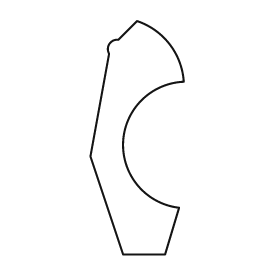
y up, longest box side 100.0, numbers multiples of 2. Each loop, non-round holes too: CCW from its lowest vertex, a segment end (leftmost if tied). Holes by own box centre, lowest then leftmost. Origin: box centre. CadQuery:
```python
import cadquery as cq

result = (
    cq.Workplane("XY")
    .moveTo(-6.0, -50.0)
    .lineTo(12.0, -50.0)
    .lineTo(18.0, -30.0)
    .threePointArc((-6.0, -2.0), (20.0, 24.0))
    .threePointArc((14.0, 40.0), (0.0, 50.0))
    .lineTo(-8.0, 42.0)
    .threePointArc((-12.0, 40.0), (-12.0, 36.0))
    .lineTo(-20.0, -8.0)
    .close()
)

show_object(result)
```